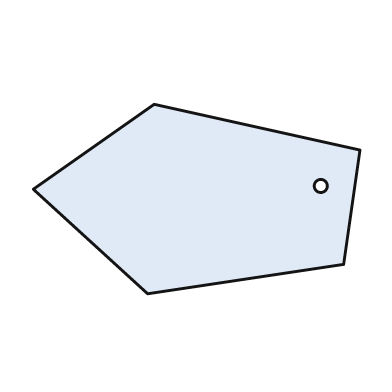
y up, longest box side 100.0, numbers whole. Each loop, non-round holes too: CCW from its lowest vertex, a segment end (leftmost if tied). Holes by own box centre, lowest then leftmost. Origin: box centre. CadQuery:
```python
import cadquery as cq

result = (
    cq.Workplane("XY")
    .moveTo(-15.0, -29.0)
    .lineTo(45.0, -20.0)
    .lineTo(50.0, 15.0)
    .lineTo(-13.0, 29.0)
    .lineTo(-50.0, 3.0)
    .close()
    .moveTo(38.0, 4.0)
    .circle(2.0)
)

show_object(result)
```